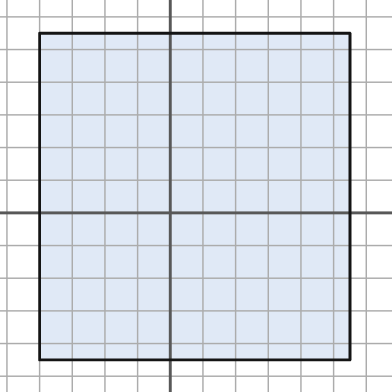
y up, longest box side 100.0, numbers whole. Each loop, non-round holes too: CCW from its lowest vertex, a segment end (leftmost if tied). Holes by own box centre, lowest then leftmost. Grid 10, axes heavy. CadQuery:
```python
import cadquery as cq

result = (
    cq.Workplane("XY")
    .moveTo(-40.0, -45.0)
    .lineTo(55.0, -45.0)
    .lineTo(55.0, 55.0)
    .lineTo(-40.0, 55.0)
    .close()
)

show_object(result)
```